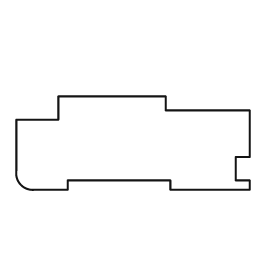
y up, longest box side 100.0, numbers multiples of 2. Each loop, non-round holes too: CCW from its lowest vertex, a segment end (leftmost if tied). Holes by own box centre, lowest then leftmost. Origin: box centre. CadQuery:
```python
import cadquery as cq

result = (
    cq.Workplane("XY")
    .moveTo(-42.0, -20.0)
    .lineTo(-28.0, -20.0)
    .lineTo(-28.0, -16.0)
    .lineTo(16.0, -16.0)
    .lineTo(16.0, -20.0)
    .lineTo(50.0, -20.0)
    .lineTo(50.0, -16.0)
    .lineTo(44.0, -16.0)
    .lineTo(44.0, -6.0)
    .lineTo(50.0, -6.0)
    .lineTo(50.0, 14.0)
    .lineTo(14.0, 14.0)
    .lineTo(14.0, 20.0)
    .lineTo(-32.0, 20.0)
    .lineTo(-32.0, 10.0)
    .lineTo(-50.0, 10.0)
    .lineTo(-50.0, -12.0)
    .threePointArc((-48.0, -18.0), (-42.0, -20.0))
    .close()
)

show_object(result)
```